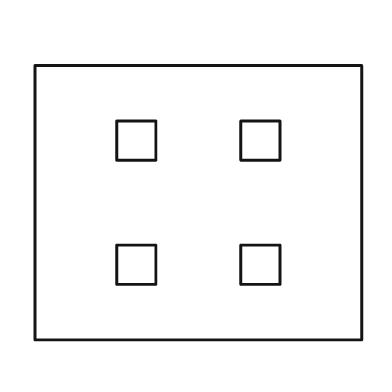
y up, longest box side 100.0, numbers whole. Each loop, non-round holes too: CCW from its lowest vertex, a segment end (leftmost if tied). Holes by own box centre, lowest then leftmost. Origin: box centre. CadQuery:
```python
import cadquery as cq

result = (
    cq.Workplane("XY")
    .moveTo(-50.0, -42.0)
    .lineTo(50.0, -42.0)
    .lineTo(50.0, 42.0)
    .lineTo(-50.0, 42.0)
    .close()
    .moveTo(-25.0, -25.0)
    .lineTo(-13.0, -25.0)
    .lineTo(-13.0, -13.0)
    .lineTo(-25.0, -13.0)
    .close()
    .moveTo(13.0, -25.0)
    .lineTo(25.0, -25.0)
    .lineTo(25.0, -13.0)
    .lineTo(13.0, -13.0)
    .close()
    .moveTo(-25.0, 13.0)
    .lineTo(-13.0, 13.0)
    .lineTo(-13.0, 25.0)
    .lineTo(-25.0, 25.0)
    .close()
    .moveTo(13.0, 13.0)
    .lineTo(25.0, 13.0)
    .lineTo(25.0, 25.0)
    .lineTo(13.0, 25.0)
    .close()
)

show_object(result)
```